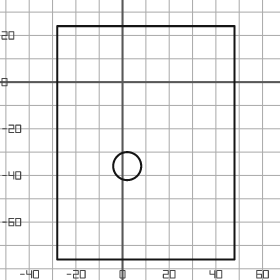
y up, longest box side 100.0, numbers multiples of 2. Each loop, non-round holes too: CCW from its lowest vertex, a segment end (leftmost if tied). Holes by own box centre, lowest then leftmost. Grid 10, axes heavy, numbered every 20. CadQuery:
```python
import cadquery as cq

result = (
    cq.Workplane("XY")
    .moveTo(-28.0, -76.0)
    .lineTo(48.0, -76.0)
    .lineTo(48.0, 24.0)
    .lineTo(-28.0, 24.0)
    .close()
    .moveTo(2.0, -36.0)
    .circle(6.0)
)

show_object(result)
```